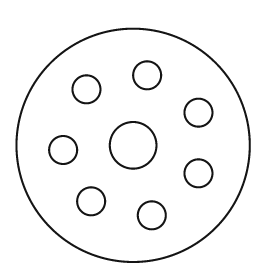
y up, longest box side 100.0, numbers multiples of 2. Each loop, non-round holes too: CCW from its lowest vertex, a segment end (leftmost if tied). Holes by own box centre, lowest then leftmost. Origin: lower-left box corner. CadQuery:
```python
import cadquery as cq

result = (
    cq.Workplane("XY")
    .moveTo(50.0, 50.0)
    .circle(50.0)
    .moveTo(58.0, 20.0)
    .circle(6.0)
    .moveTo(32.0, 26.0)
    .circle(6.0)
    .moveTo(78.0, 38.0)
    .circle(6.0)
    .moveTo(20.0, 48.0)
    .circle(6.0)
    .moveTo(50.0, 50.0)
    .circle(10.0)
    .moveTo(78.0, 64.0)
    .circle(6.0)
    .moveTo(30.0, 74.0)
    .circle(6.0)
    .moveTo(56.0, 80.0)
    .circle(6.0)
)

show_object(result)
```